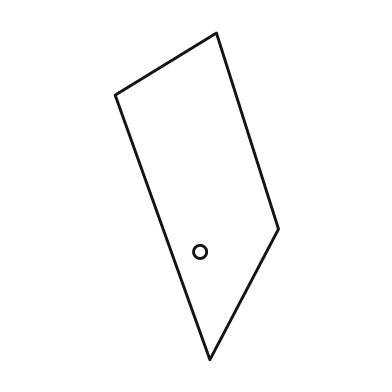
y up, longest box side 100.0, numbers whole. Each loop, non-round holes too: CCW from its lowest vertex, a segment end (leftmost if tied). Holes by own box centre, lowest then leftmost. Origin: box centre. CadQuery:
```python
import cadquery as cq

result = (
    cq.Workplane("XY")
    .moveTo(4.0, -50.0)
    .lineTo(25.0, -10.0)
    .lineTo(6.0, 50.0)
    .lineTo(-25.0, 31.0)
    .close()
    .moveTo(1.0, -17.0)
    .circle(2.0)
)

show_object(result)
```